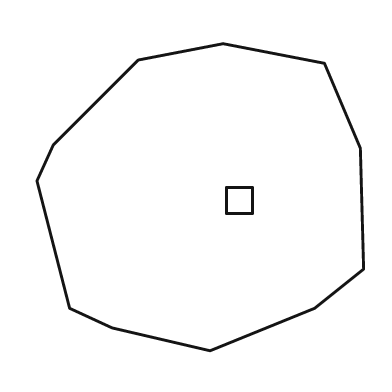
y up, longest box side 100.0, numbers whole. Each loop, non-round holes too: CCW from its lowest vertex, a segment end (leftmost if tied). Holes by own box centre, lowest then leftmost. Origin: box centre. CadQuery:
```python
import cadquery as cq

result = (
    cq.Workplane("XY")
    .moveTo(3.0, -47.0)
    .lineTo(35.0, -34.0)
    .lineTo(50.0, -22.0)
    .lineTo(49.0, 15.0)
    .lineTo(38.0, 41.0)
    .lineTo(7.0, 47.0)
    .lineTo(-19.0, 42.0)
    .lineTo(-45.0, 16.0)
    .lineTo(-50.0, 5.0)
    .lineTo(-40.0, -34.0)
    .lineTo(-27.0, -40.0)
    .close()
    .moveTo(8.0, -5.0)
    .lineTo(16.0, -5.0)
    .lineTo(16.0, 3.0)
    .lineTo(8.0, 3.0)
    .close()
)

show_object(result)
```